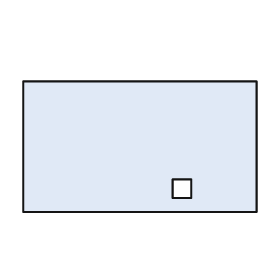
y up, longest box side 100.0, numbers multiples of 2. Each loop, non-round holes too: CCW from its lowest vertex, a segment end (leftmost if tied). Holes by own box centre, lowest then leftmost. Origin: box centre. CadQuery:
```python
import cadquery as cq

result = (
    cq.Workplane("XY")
    .moveTo(-50.0, -28.0)
    .lineTo(50.0, -28.0)
    .lineTo(50.0, 28.0)
    .lineTo(-50.0, 28.0)
    .close()
    .moveTo(14.0, -22.0)
    .lineTo(22.0, -22.0)
    .lineTo(22.0, -14.0)
    .lineTo(14.0, -14.0)
    .close()
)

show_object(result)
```